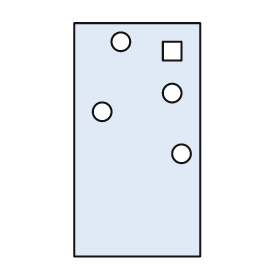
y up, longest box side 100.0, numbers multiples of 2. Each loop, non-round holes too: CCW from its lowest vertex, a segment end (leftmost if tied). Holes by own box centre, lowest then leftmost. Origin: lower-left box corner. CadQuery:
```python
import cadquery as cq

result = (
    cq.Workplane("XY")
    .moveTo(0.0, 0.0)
    .lineTo(54.0, 0.0)
    .lineTo(54.0, 100.0)
    .lineTo(0.0, 100.0)
    .close()
    .moveTo(46.0, 44.0)
    .circle(4.0)
    .moveTo(12.0, 62.0)
    .circle(4.0)
    .moveTo(42.0, 70.0)
    .circle(4.0)
    .moveTo(38.0, 84.0)
    .lineTo(46.0, 84.0)
    .lineTo(46.0, 92.0)
    .lineTo(38.0, 92.0)
    .close()
    .moveTo(20.0, 92.0)
    .circle(4.0)
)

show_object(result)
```